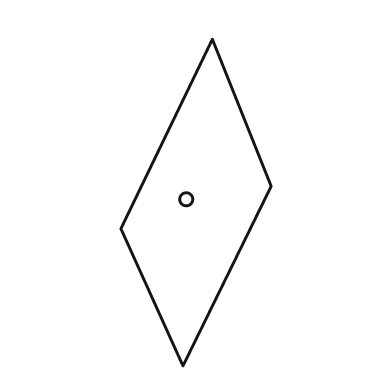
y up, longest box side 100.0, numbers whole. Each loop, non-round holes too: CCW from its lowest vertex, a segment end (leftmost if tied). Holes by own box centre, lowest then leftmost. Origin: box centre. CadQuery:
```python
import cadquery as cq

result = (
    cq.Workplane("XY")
    .moveTo(-4.0, -50.0)
    .lineTo(23.0, 5.0)
    .lineTo(5.0, 50.0)
    .lineTo(-23.0, -8.0)
    .close()
    .moveTo(-3.0, 1.0)
    .circle(2.0)
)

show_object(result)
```